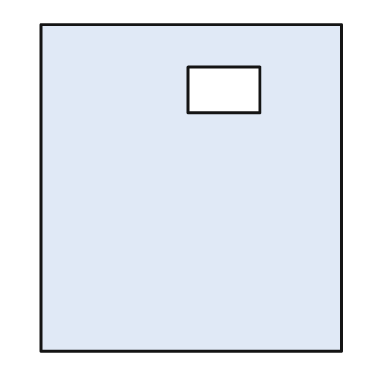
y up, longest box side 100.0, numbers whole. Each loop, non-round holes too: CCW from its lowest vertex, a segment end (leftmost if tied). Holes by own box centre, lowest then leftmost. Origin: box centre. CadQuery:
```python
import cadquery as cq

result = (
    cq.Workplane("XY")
    .moveTo(-46.0, -50.0)
    .lineTo(46.0, -50.0)
    .lineTo(46.0, 50.0)
    .lineTo(-46.0, 50.0)
    .close()
    .moveTo(-1.0, 23.0)
    .lineTo(21.0, 23.0)
    .lineTo(21.0, 37.0)
    .lineTo(-1.0, 37.0)
    .close()
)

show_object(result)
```